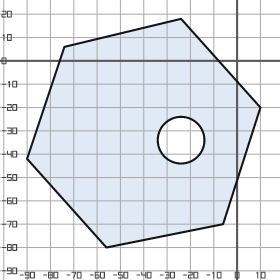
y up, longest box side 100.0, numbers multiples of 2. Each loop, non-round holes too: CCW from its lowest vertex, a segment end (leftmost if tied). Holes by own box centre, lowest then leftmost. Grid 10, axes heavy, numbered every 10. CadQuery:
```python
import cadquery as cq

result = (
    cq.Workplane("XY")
    .moveTo(-56.0, -80.0)
    .lineTo(-6.0, -70.0)
    .lineTo(10.0, -20.0)
    .lineTo(-24.0, 18.0)
    .lineTo(-74.0, 6.0)
    .lineTo(-90.0, -42.0)
    .close()
    .moveTo(-24.0, -34.0)
    .circle(10.0)
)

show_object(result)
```